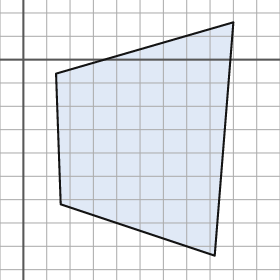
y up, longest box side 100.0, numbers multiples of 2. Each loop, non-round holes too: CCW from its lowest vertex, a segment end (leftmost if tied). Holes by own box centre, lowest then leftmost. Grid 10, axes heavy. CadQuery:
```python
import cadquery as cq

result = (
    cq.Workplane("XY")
    .moveTo(82.0, -84.0)
    .lineTo(90.0, 16.0)
    .lineTo(14.0, -6.0)
    .lineTo(16.0, -62.0)
    .close()
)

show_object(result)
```